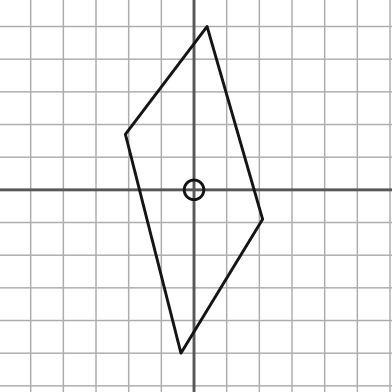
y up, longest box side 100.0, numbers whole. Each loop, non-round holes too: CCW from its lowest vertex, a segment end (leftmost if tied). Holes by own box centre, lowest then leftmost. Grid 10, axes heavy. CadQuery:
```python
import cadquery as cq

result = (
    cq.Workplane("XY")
    .moveTo(-4.0, -50.0)
    .lineTo(21.0, -9.0)
    .lineTo(4.0, 50.0)
    .lineTo(-21.0, 17.0)
    .close()
    .moveTo(0.0, 0.0)
    .circle(3.0)
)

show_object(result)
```